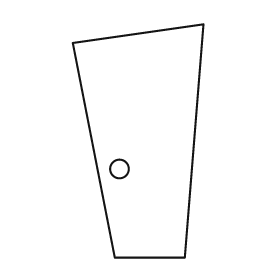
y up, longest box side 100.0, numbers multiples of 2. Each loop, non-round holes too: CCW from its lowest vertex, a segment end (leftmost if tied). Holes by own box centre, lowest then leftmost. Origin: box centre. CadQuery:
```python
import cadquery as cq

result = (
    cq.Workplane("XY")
    .moveTo(-10.0, -50.0)
    .lineTo(20.0, -50.0)
    .lineTo(28.0, 50.0)
    .lineTo(-28.0, 42.0)
    .close()
    .moveTo(-8.0, -12.0)
    .circle(4.0)
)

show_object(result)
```